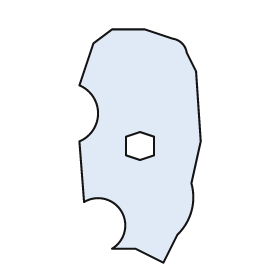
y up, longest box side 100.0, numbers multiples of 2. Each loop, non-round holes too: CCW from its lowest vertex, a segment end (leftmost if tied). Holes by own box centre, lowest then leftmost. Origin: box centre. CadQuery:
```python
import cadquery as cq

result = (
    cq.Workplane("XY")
    .moveTo(10.0, -50.0)
    .lineTo(16.0, -38.0)
    .threePointArc((22.0, -28.0), (22.0, -16.0))
    .lineTo(26.0, 2.0)
    .lineTo(24.0, 32.0)
    .lineTo(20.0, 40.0)
    .threePointArc((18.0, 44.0), (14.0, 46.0))
    .lineTo(2.0, 50.0)
    .lineTo(-12.0, 50.0)
    .lineTo(-20.0, 44.0)
    .lineTo(-26.0, 26.0)
    .threePointArc((-18.0, 14.0), (-26.0, 2.0))
    .lineTo(-24.0, -24.0)
    .threePointArc((-8.0, -28.0), (-12.0, -44.0))
    .lineTo(-2.0, -44.0)
    .close()
    .moveTo(0.0, -6.0)
    .lineTo(6.0, -4.0)
    .lineTo(6.0, 4.0)
    .lineTo(0.0, 6.0)
    .lineTo(-6.0, 4.0)
    .lineTo(-6.0, -4.0)
    .close()
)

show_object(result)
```